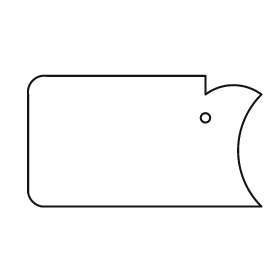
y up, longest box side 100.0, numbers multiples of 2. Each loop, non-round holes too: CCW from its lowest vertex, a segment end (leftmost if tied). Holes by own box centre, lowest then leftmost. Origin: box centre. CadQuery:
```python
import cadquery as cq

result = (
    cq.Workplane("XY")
    .moveTo(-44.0, -28.0)
    .lineTo(50.0, -28.0)
    .threePointArc((40.0, -4.0), (50.0, 20.0))
    .threePointArc((38.0, 24.0), (26.0, 20.0))
    .lineTo(26.0, 28.0)
    .lineTo(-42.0, 28.0)
    .threePointArc((-48.0, 26.0), (-50.0, 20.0))
    .lineTo(-50.0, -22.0)
    .threePointArc((-48.0, -26.0), (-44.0, -28.0))
    .close()
    .moveTo(26.0, 10.0)
    .circle(2.0)
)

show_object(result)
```